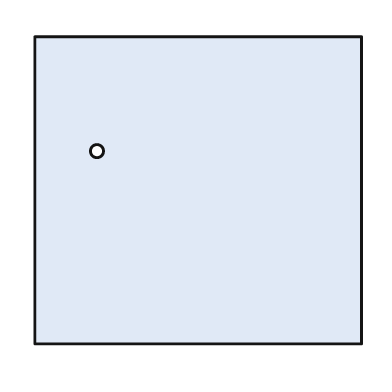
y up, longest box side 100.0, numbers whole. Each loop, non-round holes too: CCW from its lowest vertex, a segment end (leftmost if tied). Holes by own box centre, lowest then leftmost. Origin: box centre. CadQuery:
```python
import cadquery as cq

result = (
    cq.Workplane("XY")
    .moveTo(-50.0, -47.0)
    .lineTo(50.0, -47.0)
    .lineTo(50.0, 47.0)
    .lineTo(-50.0, 47.0)
    .close()
    .moveTo(-31.0, 12.0)
    .circle(2.0)
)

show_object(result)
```